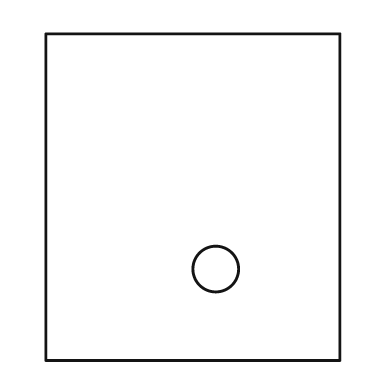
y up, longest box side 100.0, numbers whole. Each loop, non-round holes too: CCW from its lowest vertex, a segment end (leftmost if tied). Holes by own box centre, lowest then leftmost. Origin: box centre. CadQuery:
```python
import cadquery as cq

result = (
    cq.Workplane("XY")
    .moveTo(-45.0, -50.0)
    .lineTo(45.0, -50.0)
    .lineTo(45.0, 50.0)
    .lineTo(-45.0, 50.0)
    .close()
    .moveTo(7.0, -22.0)
    .circle(7.0)
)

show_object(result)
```